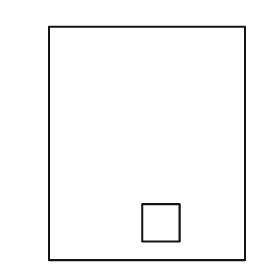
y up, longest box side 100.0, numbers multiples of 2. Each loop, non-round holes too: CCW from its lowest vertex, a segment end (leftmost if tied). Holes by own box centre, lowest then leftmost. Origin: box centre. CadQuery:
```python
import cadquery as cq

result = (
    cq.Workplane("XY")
    .moveTo(-42.0, -50.0)
    .lineTo(42.0, -50.0)
    .lineTo(42.0, 50.0)
    .lineTo(-42.0, 50.0)
    .close()
    .moveTo(-2.0, -42.0)
    .lineTo(14.0, -42.0)
    .lineTo(14.0, -26.0)
    .lineTo(-2.0, -26.0)
    .close()
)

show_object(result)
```